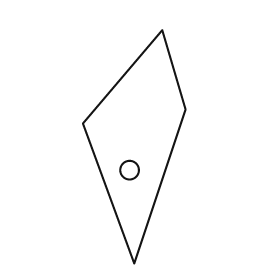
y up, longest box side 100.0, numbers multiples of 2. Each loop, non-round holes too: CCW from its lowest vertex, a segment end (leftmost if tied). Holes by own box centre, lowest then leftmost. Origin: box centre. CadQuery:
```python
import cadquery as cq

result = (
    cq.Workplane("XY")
    .moveTo(0.0, -50.0)
    .lineTo(22.0, 16.0)
    .lineTo(12.0, 50.0)
    .lineTo(-22.0, 10.0)
    .close()
    .moveTo(-2.0, -10.0)
    .circle(4.0)
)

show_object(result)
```